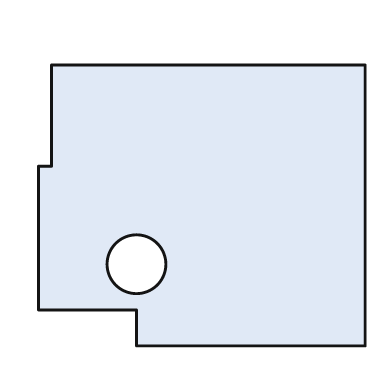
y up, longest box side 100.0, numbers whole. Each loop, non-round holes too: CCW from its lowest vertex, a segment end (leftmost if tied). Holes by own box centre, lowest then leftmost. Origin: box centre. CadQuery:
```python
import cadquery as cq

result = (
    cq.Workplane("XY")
    .moveTo(-20.0, -43.0)
    .lineTo(50.0, -43.0)
    .lineTo(50.0, 43.0)
    .lineTo(-46.0, 43.0)
    .lineTo(-46.0, 12.0)
    .lineTo(-50.0, 12.0)
    .lineTo(-50.0, -32.0)
    .lineTo(-20.0, -32.0)
    .close()
    .moveTo(-20.0, -18.0)
    .circle(9.0)
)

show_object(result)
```